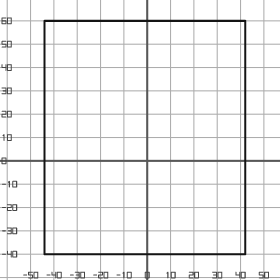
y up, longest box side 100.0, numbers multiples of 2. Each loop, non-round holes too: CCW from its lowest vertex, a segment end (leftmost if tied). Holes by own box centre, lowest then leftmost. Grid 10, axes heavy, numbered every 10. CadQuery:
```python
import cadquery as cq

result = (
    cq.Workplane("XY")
    .moveTo(-44.0, -40.0)
    .lineTo(42.0, -40.0)
    .lineTo(42.0, 60.0)
    .lineTo(-44.0, 60.0)
    .close()
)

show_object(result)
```